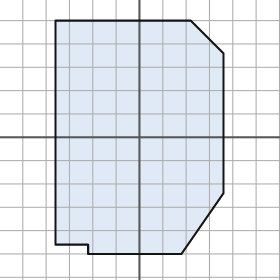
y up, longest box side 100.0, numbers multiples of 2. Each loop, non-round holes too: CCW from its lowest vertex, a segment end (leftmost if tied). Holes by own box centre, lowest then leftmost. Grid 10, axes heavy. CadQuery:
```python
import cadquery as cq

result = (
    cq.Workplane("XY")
    .moveTo(-22.0, -50.0)
    .lineTo(18.0, -50.0)
    .lineTo(36.0, -24.0)
    .lineTo(36.0, 36.0)
    .lineTo(22.0, 50.0)
    .lineTo(-36.0, 50.0)
    .lineTo(-36.0, -46.0)
    .lineTo(-22.0, -46.0)
    .close()
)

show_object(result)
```